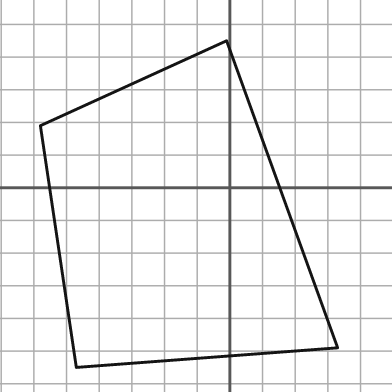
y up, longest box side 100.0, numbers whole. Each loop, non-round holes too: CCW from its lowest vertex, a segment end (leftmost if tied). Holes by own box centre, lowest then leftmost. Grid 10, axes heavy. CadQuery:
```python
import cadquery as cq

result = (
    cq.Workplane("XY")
    .moveTo(-47.0, -55.0)
    .lineTo(33.0, -49.0)
    .lineTo(-1.0, 45.0)
    .lineTo(-58.0, 19.0)
    .close()
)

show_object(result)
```